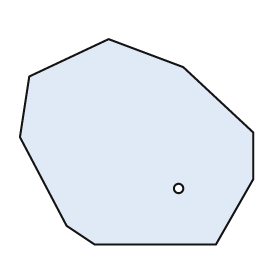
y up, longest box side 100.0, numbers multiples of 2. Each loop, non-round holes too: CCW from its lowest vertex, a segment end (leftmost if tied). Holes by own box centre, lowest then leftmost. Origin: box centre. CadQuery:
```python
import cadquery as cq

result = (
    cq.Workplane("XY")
    .moveTo(-18.0, -44.0)
    .lineTo(34.0, -44.0)
    .lineTo(50.0, -16.0)
    .lineTo(50.0, 4.0)
    .lineTo(20.0, 32.0)
    .lineTo(-12.0, 44.0)
    .lineTo(-46.0, 28.0)
    .lineTo(-50.0, 2.0)
    .lineTo(-30.0, -36.0)
    .close()
    .moveTo(18.0, -20.0)
    .circle(2.0)
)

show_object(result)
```